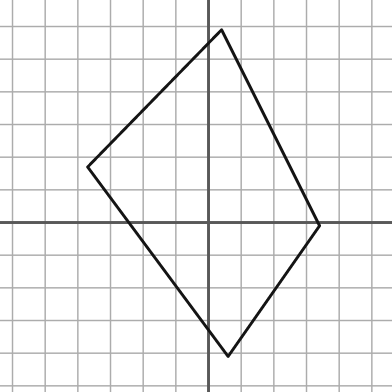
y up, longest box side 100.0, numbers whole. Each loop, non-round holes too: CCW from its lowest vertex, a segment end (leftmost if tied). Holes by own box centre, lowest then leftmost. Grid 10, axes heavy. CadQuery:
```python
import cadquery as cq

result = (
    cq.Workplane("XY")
    .moveTo(6.0, -41.0)
    .lineTo(34.0, -1.0)
    .lineTo(4.0, 59.0)
    .lineTo(-37.0, 17.0)
    .close()
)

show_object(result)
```